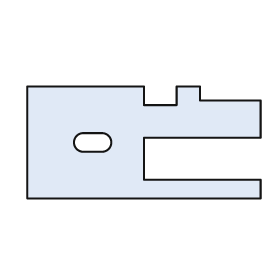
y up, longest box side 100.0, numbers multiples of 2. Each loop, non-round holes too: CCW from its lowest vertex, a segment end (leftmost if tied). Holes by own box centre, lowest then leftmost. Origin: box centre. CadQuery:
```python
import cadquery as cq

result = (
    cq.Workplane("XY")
    .moveTo(-50.0, -24.0)
    .lineTo(50.0, -24.0)
    .lineTo(50.0, -16.0)
    .lineTo(0.0, -16.0)
    .lineTo(0.0, 2.0)
    .lineTo(50.0, 2.0)
    .lineTo(50.0, 18.0)
    .lineTo(24.0, 18.0)
    .lineTo(24.0, 24.0)
    .lineTo(14.0, 24.0)
    .lineTo(14.0, 16.0)
    .lineTo(0.0, 16.0)
    .lineTo(0.0, 24.0)
    .lineTo(-50.0, 24.0)
    .close()
    .moveTo(-26.0, -4.0)
    .lineTo(-18.0, -4.0)
    .threePointArc((-14.0, 0.0), (-18.0, 4.0))
    .lineTo(-26.0, 4.0)
    .threePointArc((-30.0, 0.0), (-26.0, -4.0))
    .close()
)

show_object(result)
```